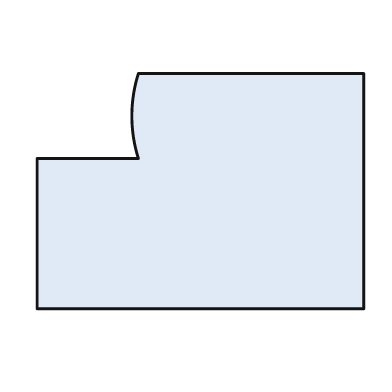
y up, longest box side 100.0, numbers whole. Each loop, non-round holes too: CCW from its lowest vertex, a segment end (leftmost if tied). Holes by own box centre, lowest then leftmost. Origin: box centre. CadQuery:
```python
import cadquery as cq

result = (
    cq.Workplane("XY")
    .moveTo(-50.0, -36.0)
    .lineTo(50.0, -36.0)
    .lineTo(50.0, 36.0)
    .lineTo(-19.0, 36.0)
    .threePointArc((-21.0, 23.0), (-19.0, 10.0))
    .lineTo(-50.0, 10.0)
    .close()
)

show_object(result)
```